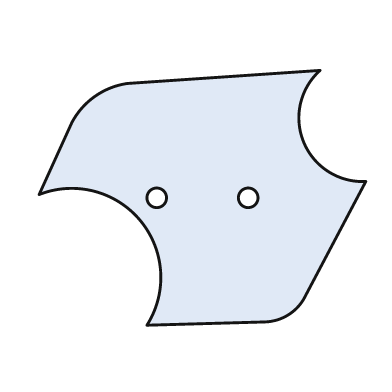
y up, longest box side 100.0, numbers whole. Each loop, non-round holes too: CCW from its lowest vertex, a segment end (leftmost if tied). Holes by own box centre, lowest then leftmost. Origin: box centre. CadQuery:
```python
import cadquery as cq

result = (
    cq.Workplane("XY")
    .moveTo(-17.0, -39.0)
    .lineTo(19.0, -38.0)
    .threePointArc((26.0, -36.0), (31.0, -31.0))
    .lineTo(50.0, 5.0)
    .threePointArc((31.0, 17.0), (36.0, 39.0))
    .lineTo(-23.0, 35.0)
    .threePointArc((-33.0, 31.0), (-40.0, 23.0))
    .lineTo(-50.0, 1.0)
    .threePointArc((-19.0, -7.0), (-17.0, -39.0))
    .close()
    .moveTo(-14.0, 0.0)
    .circle(3.0)
    .moveTo(14.0, 0.0)
    .circle(3.0)
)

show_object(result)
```